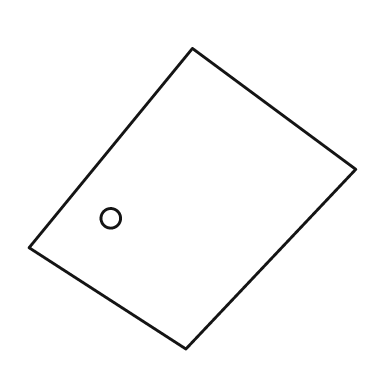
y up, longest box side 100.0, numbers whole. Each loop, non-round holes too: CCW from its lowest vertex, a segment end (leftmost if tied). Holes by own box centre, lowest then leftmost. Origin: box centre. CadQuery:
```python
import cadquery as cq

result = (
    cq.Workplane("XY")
    .moveTo(-2.0, -46.0)
    .lineTo(50.0, 9.0)
    .lineTo(0.0, 46.0)
    .lineTo(-50.0, -15.0)
    .close()
    .moveTo(-25.0, -6.0)
    .circle(3.0)
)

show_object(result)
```